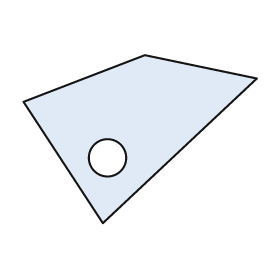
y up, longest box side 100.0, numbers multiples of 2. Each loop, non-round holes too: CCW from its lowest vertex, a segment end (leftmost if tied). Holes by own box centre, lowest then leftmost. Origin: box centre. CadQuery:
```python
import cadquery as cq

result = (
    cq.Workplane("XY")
    .moveTo(-16.0, -36.0)
    .lineTo(50.0, 26.0)
    .lineTo(2.0, 36.0)
    .lineTo(-50.0, 16.0)
    .close()
    .moveTo(-14.0, -8.0)
    .circle(8.0)
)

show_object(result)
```